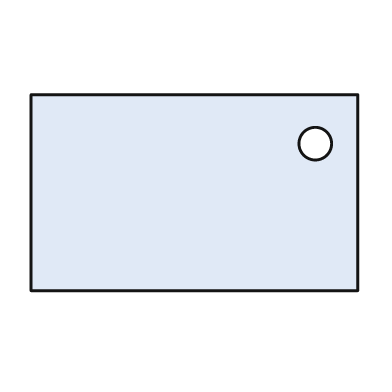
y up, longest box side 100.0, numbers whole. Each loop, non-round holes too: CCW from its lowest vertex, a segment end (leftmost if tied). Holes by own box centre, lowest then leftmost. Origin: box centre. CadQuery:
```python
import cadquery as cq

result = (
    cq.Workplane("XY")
    .moveTo(-50.0, -30.0)
    .lineTo(50.0, -30.0)
    .lineTo(50.0, 30.0)
    .lineTo(-50.0, 30.0)
    .close()
    .moveTo(37.0, 15.0)
    .circle(5.0)
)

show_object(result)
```